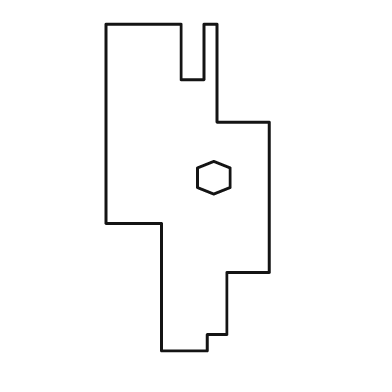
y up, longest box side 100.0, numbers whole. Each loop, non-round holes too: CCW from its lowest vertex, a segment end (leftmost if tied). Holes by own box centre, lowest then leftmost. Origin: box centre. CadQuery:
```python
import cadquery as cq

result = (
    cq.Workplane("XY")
    .moveTo(-8.0, -50.0)
    .lineTo(6.0, -50.0)
    .lineTo(6.0, -45.0)
    .lineTo(12.0, -45.0)
    .lineTo(12.0, -26.0)
    .lineTo(25.0, -26.0)
    .lineTo(25.0, 20.0)
    .lineTo(9.0, 20.0)
    .lineTo(9.0, 50.0)
    .lineTo(5.0, 50.0)
    .lineTo(5.0, 33.0)
    .lineTo(-2.0, 33.0)
    .lineTo(-2.0, 50.0)
    .lineTo(-25.0, 50.0)
    .lineTo(-25.0, -11.0)
    .lineTo(-8.0, -11.0)
    .close()
    .moveTo(8.0, -2.0)
    .lineTo(13.0, 0.0)
    .lineTo(13.0, 6.0)
    .lineTo(8.0, 8.0)
    .lineTo(3.0, 6.0)
    .lineTo(3.0, 0.0)
    .close()
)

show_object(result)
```